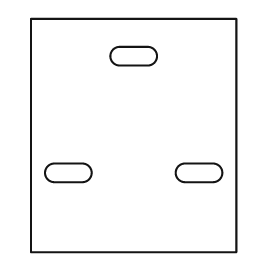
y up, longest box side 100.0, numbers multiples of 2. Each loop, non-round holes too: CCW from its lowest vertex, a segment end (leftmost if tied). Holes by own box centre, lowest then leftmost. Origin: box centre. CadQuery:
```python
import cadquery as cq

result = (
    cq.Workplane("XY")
    .moveTo(-44.0, -50.0)
    .lineTo(44.0, -50.0)
    .lineTo(44.0, 50.0)
    .lineTo(-44.0, 50.0)
    .close()
    .moveTo(-34.0, -20.0)
    .lineTo(-22.0, -20.0)
    .threePointArc((-18.0, -16.0), (-22.0, -12.0))
    .lineTo(-34.0, -12.0)
    .threePointArc((-38.0, -16.0), (-34.0, -20.0))
    .close()
    .moveTo(22.0, -20.0)
    .lineTo(34.0, -20.0)
    .threePointArc((38.0, -16.0), (34.0, -12.0))
    .lineTo(22.0, -12.0)
    .threePointArc((18.0, -16.0), (22.0, -20.0))
    .close()
    .moveTo(-6.0, 30.0)
    .lineTo(6.0, 30.0)
    .threePointArc((10.0, 34.0), (6.0, 38.0))
    .lineTo(-6.0, 38.0)
    .threePointArc((-10.0, 34.0), (-6.0, 30.0))
    .close()
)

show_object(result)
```